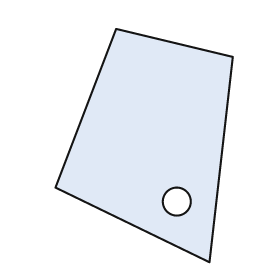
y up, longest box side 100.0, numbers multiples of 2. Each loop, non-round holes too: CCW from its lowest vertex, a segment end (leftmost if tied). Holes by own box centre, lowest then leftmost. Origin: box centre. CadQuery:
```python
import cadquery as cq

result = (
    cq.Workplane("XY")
    .moveTo(28.0, -50.0)
    .lineTo(38.0, 38.0)
    .lineTo(-12.0, 50.0)
    .lineTo(-38.0, -18.0)
    .close()
    .moveTo(14.0, -24.0)
    .circle(6.0)
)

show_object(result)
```